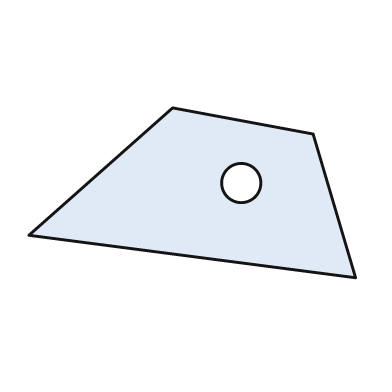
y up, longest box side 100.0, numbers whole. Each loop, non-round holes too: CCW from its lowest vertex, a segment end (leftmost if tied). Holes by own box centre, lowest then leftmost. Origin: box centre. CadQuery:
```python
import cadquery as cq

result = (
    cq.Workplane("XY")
    .moveTo(50.0, -26.0)
    .lineTo(37.0, 18.0)
    .lineTo(-6.0, 26.0)
    .lineTo(-50.0, -13.0)
    .close()
    .moveTo(15.0, 3.0)
    .circle(6.0)
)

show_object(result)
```